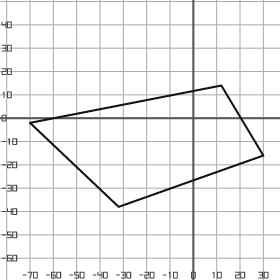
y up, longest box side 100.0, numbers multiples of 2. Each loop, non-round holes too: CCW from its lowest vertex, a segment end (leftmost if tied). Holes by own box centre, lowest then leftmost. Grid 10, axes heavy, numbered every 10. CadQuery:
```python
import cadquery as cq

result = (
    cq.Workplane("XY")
    .moveTo(-32.0, -38.0)
    .lineTo(30.0, -16.0)
    .lineTo(12.0, 14.0)
    .lineTo(-70.0, -2.0)
    .close()
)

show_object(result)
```